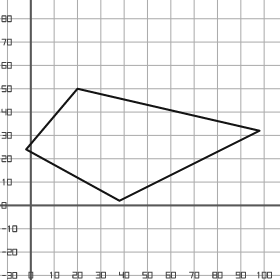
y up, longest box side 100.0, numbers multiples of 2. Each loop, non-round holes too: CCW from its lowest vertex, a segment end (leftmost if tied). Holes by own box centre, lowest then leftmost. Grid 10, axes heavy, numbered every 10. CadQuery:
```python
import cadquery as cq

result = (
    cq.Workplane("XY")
    .moveTo(38.0, 2.0)
    .lineTo(98.0, 32.0)
    .lineTo(20.0, 50.0)
    .lineTo(-2.0, 24.0)
    .close()
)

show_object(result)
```